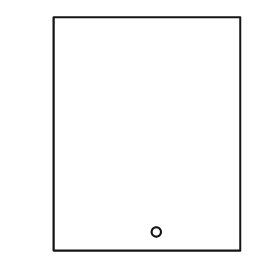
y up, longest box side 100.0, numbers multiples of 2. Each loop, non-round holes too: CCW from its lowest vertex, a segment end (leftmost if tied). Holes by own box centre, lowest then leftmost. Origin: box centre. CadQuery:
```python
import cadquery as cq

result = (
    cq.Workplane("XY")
    .moveTo(-40.0, -50.0)
    .lineTo(40.0, -50.0)
    .lineTo(40.0, 50.0)
    .lineTo(-40.0, 50.0)
    .close()
    .moveTo(4.0, -42.0)
    .circle(2.0)
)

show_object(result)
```